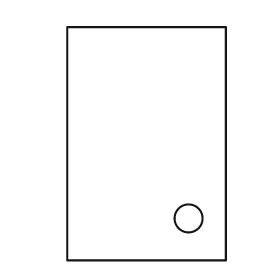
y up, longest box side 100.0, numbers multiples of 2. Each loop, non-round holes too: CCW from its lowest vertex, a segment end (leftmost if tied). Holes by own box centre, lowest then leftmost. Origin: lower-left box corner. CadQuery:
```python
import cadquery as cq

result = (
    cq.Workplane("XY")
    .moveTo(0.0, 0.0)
    .lineTo(68.0, 0.0)
    .lineTo(68.0, 100.0)
    .lineTo(0.0, 100.0)
    .close()
    .moveTo(52.0, 18.0)
    .circle(6.0)
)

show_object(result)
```